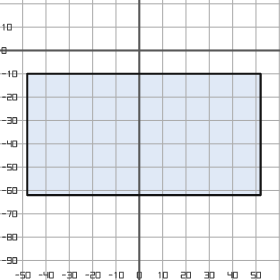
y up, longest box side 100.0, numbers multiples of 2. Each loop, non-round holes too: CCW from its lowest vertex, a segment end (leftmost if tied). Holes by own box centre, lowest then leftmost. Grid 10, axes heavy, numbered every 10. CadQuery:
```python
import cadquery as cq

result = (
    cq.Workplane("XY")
    .moveTo(-48.0, -62.0)
    .lineTo(52.0, -62.0)
    .lineTo(52.0, -10.0)
    .lineTo(-48.0, -10.0)
    .close()
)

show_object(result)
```